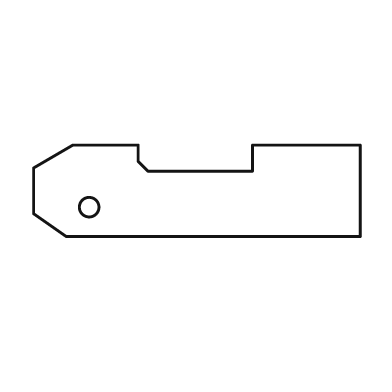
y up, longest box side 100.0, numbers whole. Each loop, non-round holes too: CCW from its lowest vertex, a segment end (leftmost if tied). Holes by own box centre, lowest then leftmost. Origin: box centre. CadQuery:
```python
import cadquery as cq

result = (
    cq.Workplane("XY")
    .moveTo(-40.0, -14.0)
    .lineTo(50.0, -14.0)
    .lineTo(50.0, 14.0)
    .lineTo(17.0, 14.0)
    .lineTo(17.0, 6.0)
    .lineTo(-15.0, 6.0)
    .lineTo(-18.0, 9.0)
    .lineTo(-18.0, 14.0)
    .lineTo(-38.0, 14.0)
    .lineTo(-50.0, 7.0)
    .lineTo(-50.0, -7.0)
    .close()
    .moveTo(-33.0, -5.0)
    .circle(3.0)
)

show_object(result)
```